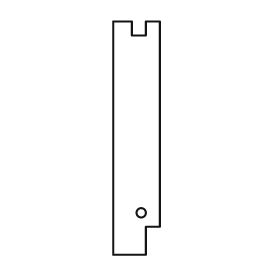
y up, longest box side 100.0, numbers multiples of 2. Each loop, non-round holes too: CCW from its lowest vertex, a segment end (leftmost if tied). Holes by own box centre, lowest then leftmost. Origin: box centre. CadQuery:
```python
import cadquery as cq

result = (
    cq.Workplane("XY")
    .moveTo(-10.0, -50.0)
    .lineTo(4.0, -50.0)
    .lineTo(4.0, -38.0)
    .lineTo(10.0, -38.0)
    .lineTo(10.0, 50.0)
    .lineTo(4.0, 50.0)
    .lineTo(4.0, 44.0)
    .lineTo(-2.0, 44.0)
    .lineTo(-2.0, 50.0)
    .lineTo(-10.0, 50.0)
    .close()
    .moveTo(2.0, -32.0)
    .circle(2.0)
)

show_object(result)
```